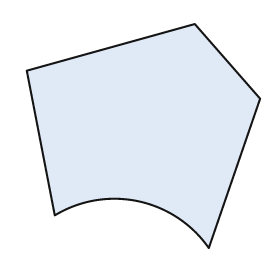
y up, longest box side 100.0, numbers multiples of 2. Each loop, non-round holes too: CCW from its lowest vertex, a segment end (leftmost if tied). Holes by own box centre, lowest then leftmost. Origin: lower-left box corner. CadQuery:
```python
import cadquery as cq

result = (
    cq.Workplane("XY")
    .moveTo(78.0, 0.0)
    .lineTo(100.0, 64.0)
    .lineTo(72.0, 96.0)
    .lineTo(0.0, 76.0)
    .lineTo(12.0, 14.0)
    .threePointArc((48.0, 20.0), (78.0, 0.0))
    .close()
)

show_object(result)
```